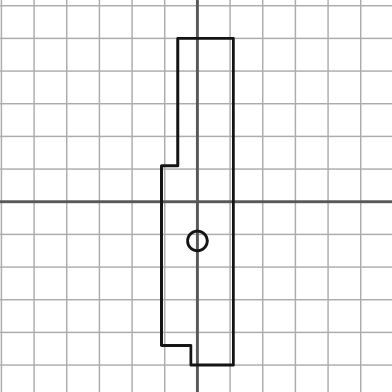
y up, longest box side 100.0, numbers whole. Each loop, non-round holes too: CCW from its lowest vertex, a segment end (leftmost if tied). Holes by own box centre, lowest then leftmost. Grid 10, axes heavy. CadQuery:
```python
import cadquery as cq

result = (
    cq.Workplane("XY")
    .moveTo(-2.0, -50.0)
    .lineTo(11.0, -50.0)
    .lineTo(11.0, 50.0)
    .lineTo(-6.0, 50.0)
    .lineTo(-6.0, 11.0)
    .lineTo(-11.0, 11.0)
    .lineTo(-11.0, -44.0)
    .lineTo(-2.0, -44.0)
    .close()
    .moveTo(0.0, -12.0)
    .circle(3.0)
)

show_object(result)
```